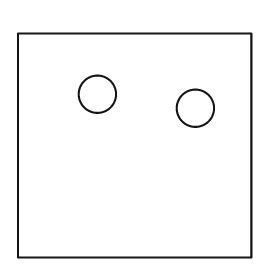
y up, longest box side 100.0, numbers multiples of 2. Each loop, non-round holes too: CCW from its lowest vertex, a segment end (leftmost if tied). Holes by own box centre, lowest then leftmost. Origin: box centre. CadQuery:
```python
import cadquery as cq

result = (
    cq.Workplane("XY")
    .moveTo(-50.0, -48.0)
    .lineTo(50.0, -48.0)
    .lineTo(50.0, 48.0)
    .lineTo(-50.0, 48.0)
    .close()
    .moveTo(26.0, 16.0)
    .circle(8.0)
    .moveTo(-16.0, 22.0)
    .circle(8.0)
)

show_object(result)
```